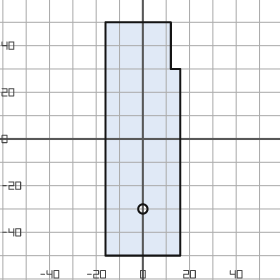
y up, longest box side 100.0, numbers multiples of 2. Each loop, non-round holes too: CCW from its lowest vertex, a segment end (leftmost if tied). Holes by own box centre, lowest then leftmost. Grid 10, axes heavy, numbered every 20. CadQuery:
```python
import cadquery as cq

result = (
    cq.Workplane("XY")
    .moveTo(-16.0, -50.0)
    .lineTo(16.0, -50.0)
    .lineTo(16.0, 30.0)
    .lineTo(12.0, 30.0)
    .lineTo(12.0, 50.0)
    .lineTo(-16.0, 50.0)
    .close()
    .moveTo(0.0, -30.0)
    .circle(2.0)
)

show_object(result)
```